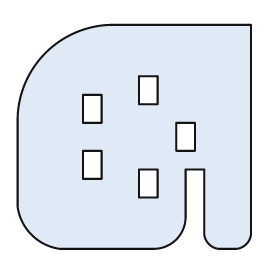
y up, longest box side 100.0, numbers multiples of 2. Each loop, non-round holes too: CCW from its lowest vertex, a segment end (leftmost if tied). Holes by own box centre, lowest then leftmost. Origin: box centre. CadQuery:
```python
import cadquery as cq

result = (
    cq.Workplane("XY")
    .moveTo(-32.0, -48.0)
    .lineTo(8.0, -48.0)
    .threePointArc((18.0, -44.0), (22.0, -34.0))
    .lineTo(22.0, -14.0)
    .lineTo(30.0, -14.0)
    .lineTo(30.0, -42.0)
    .threePointArc((32.0, -46.0), (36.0, -48.0))
    .lineTo(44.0, -48.0)
    .threePointArc((48.0, -46.0), (50.0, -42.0))
    .lineTo(50.0, 48.0)
    .lineTo(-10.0, 48.0)
    .threePointArc((-38.0, 36.0), (-50.0, 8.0))
    .lineTo(-50.0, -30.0)
    .threePointArc((-44.0, -42.0), (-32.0, -48.0))
    .close()
    .moveTo(2.0, -26.0)
    .lineTo(10.0, -26.0)
    .lineTo(10.0, -14.0)
    .lineTo(2.0, -14.0)
    .close()
    .moveTo(-22.0, -18.0)
    .lineTo(-14.0, -18.0)
    .lineTo(-14.0, -6.0)
    .lineTo(-22.0, -6.0)
    .close()
    .moveTo(18.0, -6.0)
    .lineTo(26.0, -6.0)
    .lineTo(26.0, 6.0)
    .lineTo(18.0, 6.0)
    .close()
    .moveTo(-22.0, 6.0)
    .lineTo(-14.0, 6.0)
    .lineTo(-14.0, 18.0)
    .lineTo(-22.0, 18.0)
    .close()
    .moveTo(2.0, 14.0)
    .lineTo(10.0, 14.0)
    .lineTo(10.0, 26.0)
    .lineTo(2.0, 26.0)
    .close()
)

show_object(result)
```